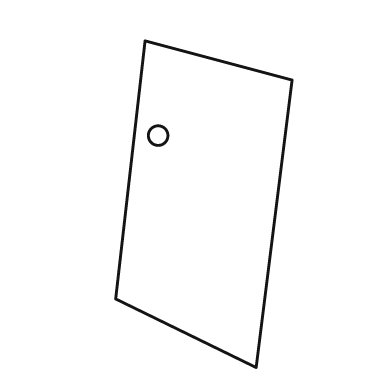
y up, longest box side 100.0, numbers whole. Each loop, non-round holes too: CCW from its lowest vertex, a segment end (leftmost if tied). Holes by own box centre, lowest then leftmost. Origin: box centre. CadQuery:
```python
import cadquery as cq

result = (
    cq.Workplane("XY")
    .moveTo(16.0, -50.0)
    .lineTo(27.0, 38.0)
    .lineTo(-18.0, 50.0)
    .lineTo(-27.0, -29.0)
    .close()
    .moveTo(-14.0, 21.0)
    .circle(3.0)
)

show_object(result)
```